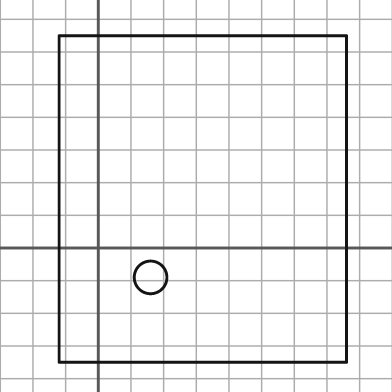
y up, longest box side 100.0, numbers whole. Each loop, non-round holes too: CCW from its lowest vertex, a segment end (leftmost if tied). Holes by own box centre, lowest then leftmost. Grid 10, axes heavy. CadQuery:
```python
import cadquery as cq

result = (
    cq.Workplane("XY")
    .moveTo(-12.0, -35.0)
    .lineTo(76.0, -35.0)
    .lineTo(76.0, 65.0)
    .lineTo(-12.0, 65.0)
    .close()
    .moveTo(16.0, -9.0)
    .circle(5.0)
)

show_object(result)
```